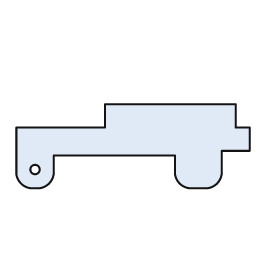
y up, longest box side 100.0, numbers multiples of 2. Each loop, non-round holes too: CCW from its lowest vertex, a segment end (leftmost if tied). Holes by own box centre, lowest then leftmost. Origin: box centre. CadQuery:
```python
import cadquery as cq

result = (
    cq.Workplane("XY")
    .moveTo(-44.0, -18.0)
    .lineTo(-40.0, -18.0)
    .threePointArc((-36.0, -16.0), (-34.0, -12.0))
    .lineTo(-34.0, -4.0)
    .lineTo(18.0, -4.0)
    .lineTo(18.0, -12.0)
    .threePointArc((20.0, -16.0), (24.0, -18.0))
    .lineTo(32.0, -18.0)
    .threePointArc((36.0, -16.0), (38.0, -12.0))
    .lineTo(38.0, -2.0)
    .lineTo(50.0, -2.0)
    .lineTo(50.0, 8.0)
    .lineTo(44.0, 8.0)
    .lineTo(44.0, 18.0)
    .lineTo(-12.0, 18.0)
    .lineTo(-12.0, 8.0)
    .lineTo(-50.0, 8.0)
    .lineTo(-50.0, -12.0)
    .threePointArc((-48.0, -16.0), (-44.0, -18.0))
    .close()
    .moveTo(-42.0, -10.0)
    .circle(2.0)
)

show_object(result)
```